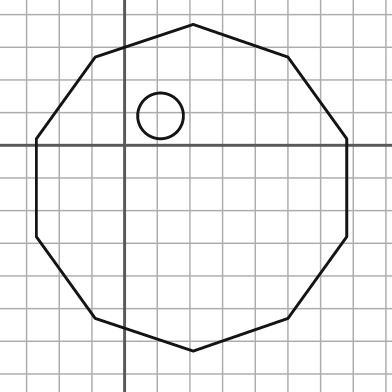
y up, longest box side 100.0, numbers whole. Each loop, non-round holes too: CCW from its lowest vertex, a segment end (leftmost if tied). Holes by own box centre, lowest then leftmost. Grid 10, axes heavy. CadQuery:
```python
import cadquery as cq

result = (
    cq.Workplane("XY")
    .moveTo(21.0, -63.0)
    .lineTo(50.0, -53.0)
    .lineTo(68.0, -28.0)
    .lineTo(68.0, 2.0)
    .lineTo(50.0, 27.0)
    .lineTo(21.0, 37.0)
    .lineTo(-9.0, 27.0)
    .lineTo(-27.0, 2.0)
    .lineTo(-27.0, -28.0)
    .lineTo(-9.0, -53.0)
    .close()
    .moveTo(11.0, 9.0)
    .circle(7.0)
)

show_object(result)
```